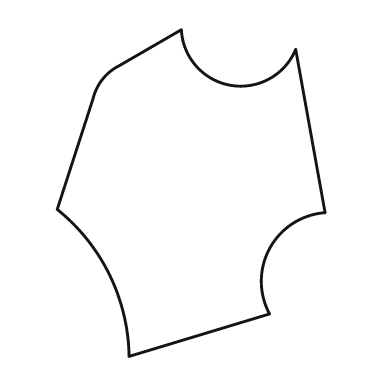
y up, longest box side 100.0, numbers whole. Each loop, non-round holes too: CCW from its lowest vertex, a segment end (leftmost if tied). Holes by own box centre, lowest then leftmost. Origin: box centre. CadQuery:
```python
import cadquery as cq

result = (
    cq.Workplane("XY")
    .moveTo(-19.0, -50.0)
    .lineTo(24.0, -37.0)
    .threePointArc((24.0, -17.0), (41.0, -6.0))
    .lineTo(32.0, 44.0)
    .threePointArc((12.0, 33.0), (-3.0, 50.0))
    .lineTo(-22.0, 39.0)
    .threePointArc((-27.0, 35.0), (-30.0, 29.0))
    .lineTo(-41.0, -5.0)
    .threePointArc((-25.0, -25.0), (-19.0, -50.0))
    .close()
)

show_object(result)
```